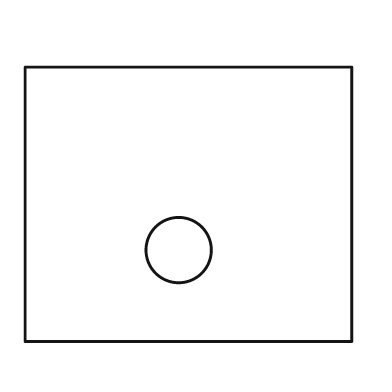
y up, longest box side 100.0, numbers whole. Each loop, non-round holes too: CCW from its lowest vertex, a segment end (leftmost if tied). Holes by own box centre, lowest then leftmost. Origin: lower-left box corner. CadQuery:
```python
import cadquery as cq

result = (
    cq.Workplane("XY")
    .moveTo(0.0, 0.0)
    .lineTo(100.0, 0.0)
    .lineTo(100.0, 84.0)
    .lineTo(0.0, 84.0)
    .close()
    .moveTo(47.0, 28.0)
    .circle(10.0)
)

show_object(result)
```